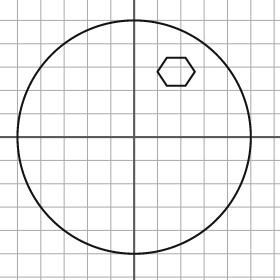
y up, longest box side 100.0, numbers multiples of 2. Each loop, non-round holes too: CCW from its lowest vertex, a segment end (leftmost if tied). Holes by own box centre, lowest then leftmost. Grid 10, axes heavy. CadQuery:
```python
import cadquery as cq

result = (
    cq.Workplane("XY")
    .moveTo(0.0, 0.0)
    .circle(50.0)
    .moveTo(14.0, 22.0)
    .lineTo(22.0, 22.0)
    .lineTo(26.0, 28.0)
    .lineTo(22.0, 34.0)
    .lineTo(14.0, 34.0)
    .lineTo(10.0, 28.0)
    .close()
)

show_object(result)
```